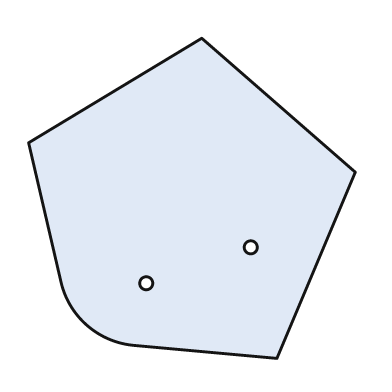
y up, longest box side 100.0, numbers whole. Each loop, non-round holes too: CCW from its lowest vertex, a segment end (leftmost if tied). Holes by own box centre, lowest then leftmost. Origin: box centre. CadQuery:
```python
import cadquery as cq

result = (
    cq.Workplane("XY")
    .moveTo(26.0, -49.0)
    .lineTo(50.0, 8.0)
    .lineTo(3.0, 49.0)
    .lineTo(-50.0, 17.0)
    .lineTo(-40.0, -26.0)
    .threePointArc((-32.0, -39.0), (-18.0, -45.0))
    .close()
    .moveTo(-14.0, -26.0)
    .circle(2.0)
    .moveTo(18.0, -15.0)
    .circle(2.0)
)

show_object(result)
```